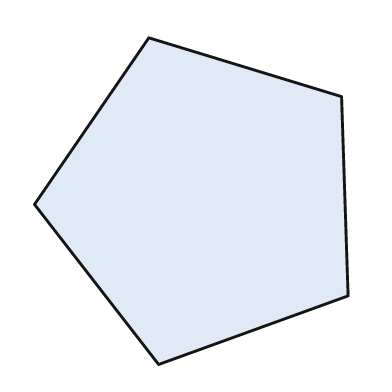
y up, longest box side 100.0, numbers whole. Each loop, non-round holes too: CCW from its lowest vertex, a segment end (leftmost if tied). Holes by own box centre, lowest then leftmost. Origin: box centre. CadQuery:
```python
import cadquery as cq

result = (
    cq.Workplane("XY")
    .moveTo(-10.0, -50.0)
    .lineTo(48.0, -29.0)
    .lineTo(46.0, 32.0)
    .lineTo(-13.0, 50.0)
    .lineTo(-48.0, -1.0)
    .close()
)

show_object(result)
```